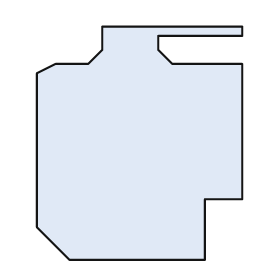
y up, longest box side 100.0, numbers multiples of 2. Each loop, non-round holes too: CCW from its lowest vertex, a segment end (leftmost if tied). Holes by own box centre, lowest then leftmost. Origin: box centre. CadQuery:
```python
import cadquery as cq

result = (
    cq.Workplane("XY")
    .moveTo(-30.0, -50.0)
    .lineTo(28.0, -50.0)
    .lineTo(28.0, -24.0)
    .lineTo(44.0, -24.0)
    .lineTo(44.0, 34.0)
    .lineTo(14.0, 34.0)
    .lineTo(8.0, 40.0)
    .lineTo(8.0, 46.0)
    .lineTo(44.0, 46.0)
    .lineTo(44.0, 50.0)
    .lineTo(-16.0, 50.0)
    .lineTo(-16.0, 40.0)
    .lineTo(-22.0, 34.0)
    .lineTo(-36.0, 34.0)
    .lineTo(-44.0, 30.0)
    .lineTo(-44.0, -36.0)
    .close()
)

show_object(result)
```